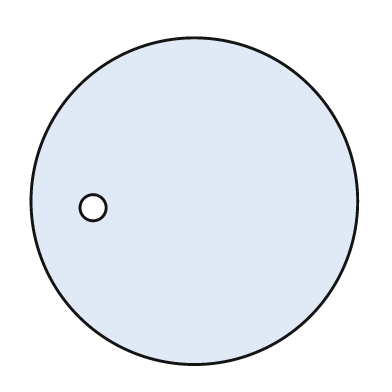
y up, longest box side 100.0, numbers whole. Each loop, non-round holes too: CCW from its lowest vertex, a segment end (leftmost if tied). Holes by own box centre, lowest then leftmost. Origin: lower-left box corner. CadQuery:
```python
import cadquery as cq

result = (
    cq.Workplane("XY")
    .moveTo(50.0, 50.0)
    .circle(50.0)
    .moveTo(19.0, 48.0)
    .circle(4.0)
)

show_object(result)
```